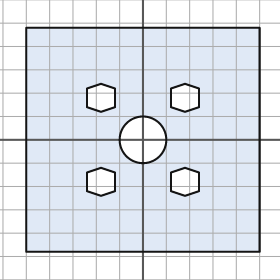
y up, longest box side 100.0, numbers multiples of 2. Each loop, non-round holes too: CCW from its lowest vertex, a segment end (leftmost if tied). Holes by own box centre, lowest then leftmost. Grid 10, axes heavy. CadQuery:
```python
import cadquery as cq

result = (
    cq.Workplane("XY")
    .moveTo(-50.0, -48.0)
    .lineTo(50.0, -48.0)
    .lineTo(50.0, 48.0)
    .lineTo(-50.0, 48.0)
    .close()
    .moveTo(-18.0, -24.0)
    .lineTo(-12.0, -22.0)
    .lineTo(-12.0, -14.0)
    .lineTo(-18.0, -12.0)
    .lineTo(-24.0, -14.0)
    .lineTo(-24.0, -22.0)
    .close()
    .moveTo(18.0, -24.0)
    .lineTo(24.0, -22.0)
    .lineTo(24.0, -14.0)
    .lineTo(18.0, -12.0)
    .lineTo(12.0, -14.0)
    .lineTo(12.0, -22.0)
    .close()
    .moveTo(0.0, 0.0)
    .circle(10.0)
    .moveTo(-18.0, 12.0)
    .lineTo(-12.0, 14.0)
    .lineTo(-12.0, 22.0)
    .lineTo(-18.0, 24.0)
    .lineTo(-24.0, 22.0)
    .lineTo(-24.0, 14.0)
    .close()
    .moveTo(18.0, 12.0)
    .lineTo(24.0, 14.0)
    .lineTo(24.0, 22.0)
    .lineTo(18.0, 24.0)
    .lineTo(12.0, 22.0)
    .lineTo(12.0, 14.0)
    .close()
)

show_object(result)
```